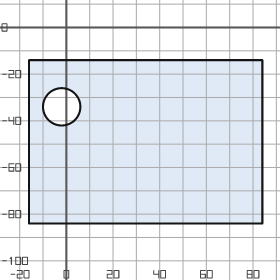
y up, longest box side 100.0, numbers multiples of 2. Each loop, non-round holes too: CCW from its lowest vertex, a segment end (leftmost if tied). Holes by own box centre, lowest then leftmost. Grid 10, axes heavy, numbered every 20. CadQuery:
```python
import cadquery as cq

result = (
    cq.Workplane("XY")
    .moveTo(-16.0, -84.0)
    .lineTo(84.0, -84.0)
    .lineTo(84.0, -14.0)
    .lineTo(-16.0, -14.0)
    .close()
    .moveTo(-2.0, -34.0)
    .circle(8.0)
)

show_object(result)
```